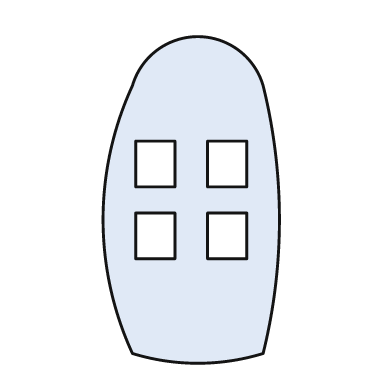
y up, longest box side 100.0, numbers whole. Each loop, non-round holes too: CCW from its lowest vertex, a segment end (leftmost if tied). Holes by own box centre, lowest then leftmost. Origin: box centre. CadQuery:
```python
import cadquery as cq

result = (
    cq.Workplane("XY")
    .moveTo(-18.0, -47.0)
    .threePointArc((2.0, -50.0), (22.0, -47.0))
    .threePointArc((27.0, -6.0), (22.0, 35.0))
    .threePointArc((2.0, 50.0), (-18.0, 35.0))
    .threePointArc((-27.0, -6.0), (-18.0, -47.0))
    .close()
    .moveTo(-17.0, -18.0)
    .lineTo(-5.0, -18.0)
    .lineTo(-5.0, -4.0)
    .lineTo(-17.0, -4.0)
    .close()
    .moveTo(5.0, -18.0)
    .lineTo(17.0, -18.0)
    .lineTo(17.0, -4.0)
    .lineTo(5.0, -4.0)
    .close()
    .moveTo(-17.0, 4.0)
    .lineTo(-5.0, 4.0)
    .lineTo(-5.0, 18.0)
    .lineTo(-17.0, 18.0)
    .close()
    .moveTo(5.0, 4.0)
    .lineTo(17.0, 4.0)
    .lineTo(17.0, 18.0)
    .lineTo(5.0, 18.0)
    .close()
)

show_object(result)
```